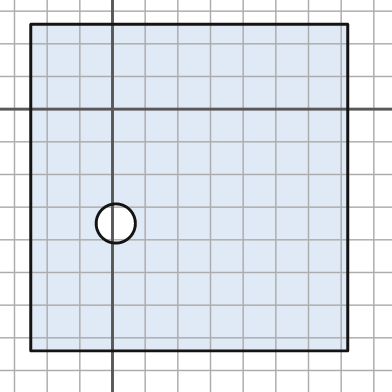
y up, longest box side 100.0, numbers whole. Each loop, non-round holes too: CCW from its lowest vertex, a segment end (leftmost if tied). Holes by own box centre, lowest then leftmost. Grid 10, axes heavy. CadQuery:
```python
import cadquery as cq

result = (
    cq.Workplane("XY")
    .moveTo(-25.0, -74.0)
    .lineTo(72.0, -74.0)
    .lineTo(72.0, 26.0)
    .lineTo(-25.0, 26.0)
    .close()
    .moveTo(1.0, -35.0)
    .circle(6.0)
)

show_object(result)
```